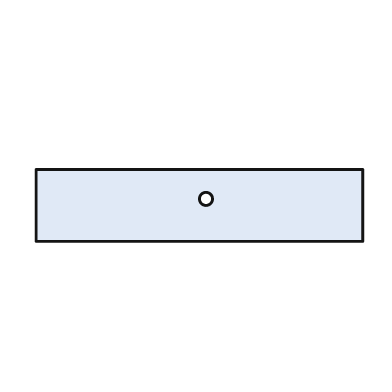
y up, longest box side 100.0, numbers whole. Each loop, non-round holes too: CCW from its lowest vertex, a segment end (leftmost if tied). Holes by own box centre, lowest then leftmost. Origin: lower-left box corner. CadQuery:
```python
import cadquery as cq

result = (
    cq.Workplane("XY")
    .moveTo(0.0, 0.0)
    .lineTo(100.0, 0.0)
    .lineTo(100.0, 22.0)
    .lineTo(0.0, 22.0)
    .close()
    .moveTo(52.0, 13.0)
    .circle(2.0)
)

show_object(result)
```